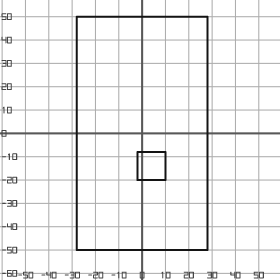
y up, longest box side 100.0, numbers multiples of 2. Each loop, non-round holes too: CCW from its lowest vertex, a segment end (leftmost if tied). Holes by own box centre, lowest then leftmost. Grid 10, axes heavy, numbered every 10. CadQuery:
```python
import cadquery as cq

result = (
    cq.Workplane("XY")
    .moveTo(-28.0, -50.0)
    .lineTo(28.0, -50.0)
    .lineTo(28.0, 50.0)
    .lineTo(-28.0, 50.0)
    .close()
    .moveTo(-2.0, -20.0)
    .lineTo(10.0, -20.0)
    .lineTo(10.0, -8.0)
    .lineTo(-2.0, -8.0)
    .close()
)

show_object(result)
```